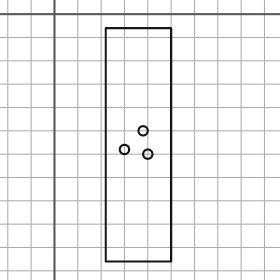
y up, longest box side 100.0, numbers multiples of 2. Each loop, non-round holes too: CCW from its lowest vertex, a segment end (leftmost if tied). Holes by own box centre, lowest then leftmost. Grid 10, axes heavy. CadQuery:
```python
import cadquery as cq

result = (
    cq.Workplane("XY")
    .moveTo(22.0, -106.0)
    .lineTo(50.0, -106.0)
    .lineTo(50.0, -6.0)
    .lineTo(22.0, -6.0)
    .close()
    .moveTo(40.0, -60.0)
    .circle(2.0)
    .moveTo(30.0, -58.0)
    .circle(2.0)
    .moveTo(38.0, -50.0)
    .circle(2.0)
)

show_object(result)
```